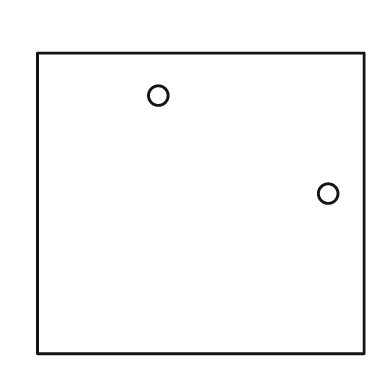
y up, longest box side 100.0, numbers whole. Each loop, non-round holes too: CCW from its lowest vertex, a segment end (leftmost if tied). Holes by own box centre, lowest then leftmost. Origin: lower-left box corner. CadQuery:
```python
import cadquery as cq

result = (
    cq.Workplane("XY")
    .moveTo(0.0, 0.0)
    .lineTo(100.0, 0.0)
    .lineTo(100.0, 92.0)
    .lineTo(0.0, 92.0)
    .close()
    .moveTo(89.0, 49.0)
    .circle(3.0)
    .moveTo(37.0, 79.0)
    .circle(3.0)
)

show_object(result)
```